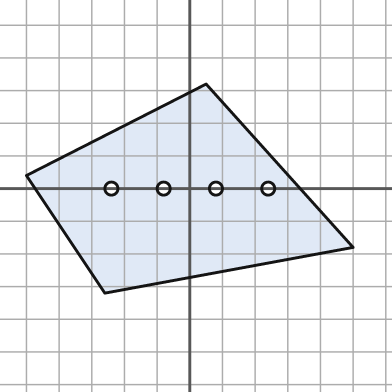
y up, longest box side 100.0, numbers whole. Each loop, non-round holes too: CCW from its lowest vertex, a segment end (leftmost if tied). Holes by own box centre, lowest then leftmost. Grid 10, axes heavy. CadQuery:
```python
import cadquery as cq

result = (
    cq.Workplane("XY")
    .moveTo(-26.0, -32.0)
    .lineTo(50.0, -18.0)
    .lineTo(5.0, 32.0)
    .lineTo(-50.0, 4.0)
    .close()
    .moveTo(-24.0, 0.0)
    .circle(2.0)
    .moveTo(-8.0, 0.0)
    .circle(2.0)
    .moveTo(8.0, 0.0)
    .circle(2.0)
    .moveTo(24.0, 0.0)
    .circle(2.0)
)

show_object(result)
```